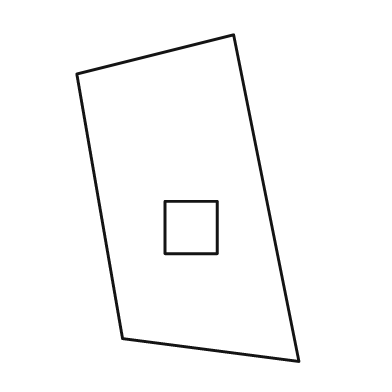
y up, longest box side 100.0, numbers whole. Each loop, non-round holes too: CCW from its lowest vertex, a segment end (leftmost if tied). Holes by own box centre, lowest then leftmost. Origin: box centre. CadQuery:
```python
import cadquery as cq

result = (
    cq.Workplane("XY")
    .moveTo(34.0, -50.0)
    .lineTo(14.0, 50.0)
    .lineTo(-34.0, 38.0)
    .lineTo(-20.0, -43.0)
    .close()
    .moveTo(-7.0, -17.0)
    .lineTo(9.0, -17.0)
    .lineTo(9.0, -1.0)
    .lineTo(-7.0, -1.0)
    .close()
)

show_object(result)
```